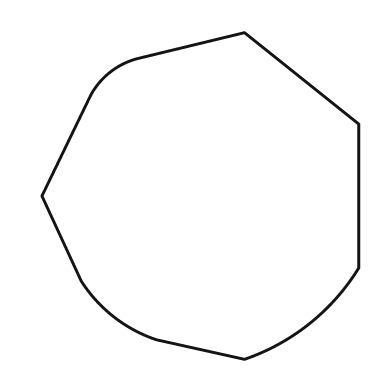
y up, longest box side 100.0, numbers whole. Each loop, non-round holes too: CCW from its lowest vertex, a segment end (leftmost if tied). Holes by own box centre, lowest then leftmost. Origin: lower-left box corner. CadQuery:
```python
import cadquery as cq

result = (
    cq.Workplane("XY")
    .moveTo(62.0, 0.0)
    .threePointArc((82.0, 11.0), (97.0, 28.0))
    .lineTo(97.0, 72.0)
    .lineTo(62.0, 100.0)
    .lineTo(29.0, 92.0)
    .threePointArc((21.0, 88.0), (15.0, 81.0))
    .lineTo(0.0, 50.0)
    .lineTo(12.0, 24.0)
    .threePointArc((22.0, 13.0), (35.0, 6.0))
    .close()
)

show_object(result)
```